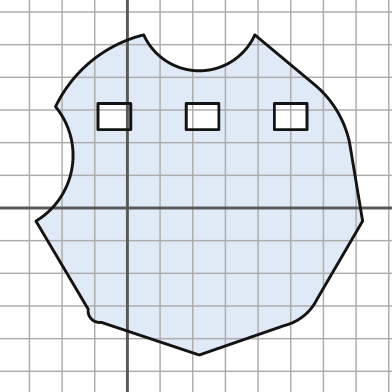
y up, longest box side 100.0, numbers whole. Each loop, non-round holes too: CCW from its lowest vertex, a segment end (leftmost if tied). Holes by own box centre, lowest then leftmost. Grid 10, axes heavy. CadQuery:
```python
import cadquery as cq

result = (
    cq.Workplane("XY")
    .moveTo(22.0, -45.0)
    .lineTo(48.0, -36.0)
    .threePointArc((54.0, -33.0), (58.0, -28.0))
    .lineTo(72.0, -4.0)
    .lineTo(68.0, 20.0)
    .threePointArc((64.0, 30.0), (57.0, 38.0))
    .lineTo(39.0, 53.0)
    .threePointArc((22.0, 42.0), (5.0, 53.0))
    .threePointArc((-11.0, 45.0), (-22.0, 31.0))
    .threePointArc((-17.0, 12.0), (-28.0, -4.0))
    .lineTo(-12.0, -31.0)
    .threePointArc((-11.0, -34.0), (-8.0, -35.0))
    .close()
    .moveTo(-9.0, 24.0)
    .lineTo(1.0, 24.0)
    .lineTo(1.0, 32.0)
    .lineTo(-9.0, 32.0)
    .close()
    .moveTo(18.0, 24.0)
    .lineTo(28.0, 24.0)
    .lineTo(28.0, 32.0)
    .lineTo(18.0, 32.0)
    .close()
    .moveTo(45.0, 24.0)
    .lineTo(55.0, 24.0)
    .lineTo(55.0, 32.0)
    .lineTo(45.0, 32.0)
    .close()
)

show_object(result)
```